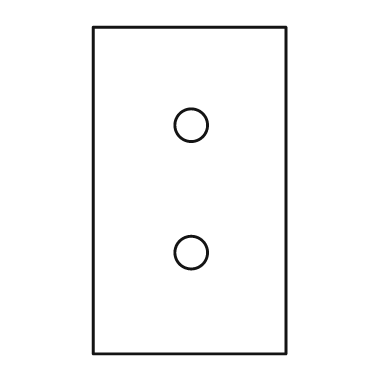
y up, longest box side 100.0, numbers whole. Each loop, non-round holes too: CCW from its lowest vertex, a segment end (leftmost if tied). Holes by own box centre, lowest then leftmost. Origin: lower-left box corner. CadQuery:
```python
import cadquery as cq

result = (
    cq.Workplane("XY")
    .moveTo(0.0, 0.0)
    .lineTo(59.0, 0.0)
    .lineTo(59.0, 100.0)
    .lineTo(0.0, 100.0)
    .close()
    .moveTo(30.0, 31.0)
    .circle(5.0)
    .moveTo(30.0, 70.0)
    .circle(5.0)
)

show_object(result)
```